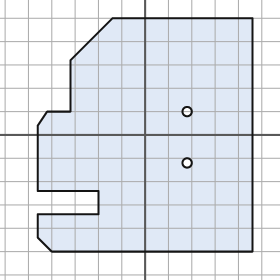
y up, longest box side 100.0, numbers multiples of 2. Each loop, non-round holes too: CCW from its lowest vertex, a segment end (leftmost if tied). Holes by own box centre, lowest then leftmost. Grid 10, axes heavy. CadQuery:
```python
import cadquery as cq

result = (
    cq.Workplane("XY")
    .moveTo(-40.0, -50.0)
    .lineTo(46.0, -50.0)
    .lineTo(46.0, 50.0)
    .lineTo(-14.0, 50.0)
    .lineTo(-32.0, 32.0)
    .lineTo(-32.0, 10.0)
    .lineTo(-42.0, 10.0)
    .lineTo(-46.0, 4.0)
    .lineTo(-46.0, -24.0)
    .lineTo(-20.0, -24.0)
    .lineTo(-20.0, -34.0)
    .lineTo(-46.0, -34.0)
    .lineTo(-46.0, -44.0)
    .close()
    .moveTo(18.0, -12.0)
    .circle(2.0)
    .moveTo(18.0, 10.0)
    .circle(2.0)
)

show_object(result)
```